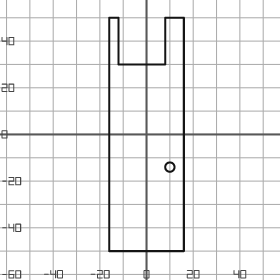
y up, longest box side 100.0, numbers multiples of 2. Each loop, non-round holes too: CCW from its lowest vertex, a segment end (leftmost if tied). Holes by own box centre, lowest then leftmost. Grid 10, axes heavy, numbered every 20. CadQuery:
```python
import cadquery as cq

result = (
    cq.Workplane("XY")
    .moveTo(-16.0, -50.0)
    .lineTo(16.0, -50.0)
    .lineTo(16.0, 50.0)
    .lineTo(8.0, 50.0)
    .lineTo(8.0, 30.0)
    .lineTo(-12.0, 30.0)
    .lineTo(-12.0, 50.0)
    .lineTo(-16.0, 50.0)
    .close()
    .moveTo(10.0, -14.0)
    .circle(2.0)
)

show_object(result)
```